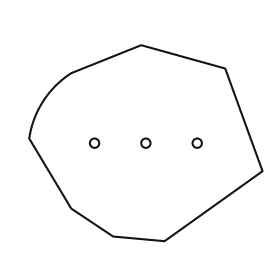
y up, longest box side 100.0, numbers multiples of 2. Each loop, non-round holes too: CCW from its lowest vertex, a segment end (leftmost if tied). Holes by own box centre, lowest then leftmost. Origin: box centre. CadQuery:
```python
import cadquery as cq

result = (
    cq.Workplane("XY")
    .moveTo(8.0, -42.0)
    .lineTo(50.0, -12.0)
    .lineTo(34.0, 32.0)
    .lineTo(-2.0, 42.0)
    .lineTo(-32.0, 30.0)
    .threePointArc((-44.0, 18.0), (-50.0, 2.0))
    .lineTo(-32.0, -28.0)
    .lineTo(-14.0, -40.0)
    .close()
    .moveTo(-22.0, 0.0)
    .circle(2.0)
    .moveTo(0.0, 0.0)
    .circle(2.0)
    .moveTo(22.0, 0.0)
    .circle(2.0)
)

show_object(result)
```